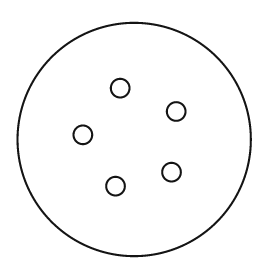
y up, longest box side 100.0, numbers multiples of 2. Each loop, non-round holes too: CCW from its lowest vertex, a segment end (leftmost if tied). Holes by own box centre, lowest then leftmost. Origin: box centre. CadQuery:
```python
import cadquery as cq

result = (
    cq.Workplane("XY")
    .moveTo(0.0, 0.0)
    .circle(50.0)
    .moveTo(-8.0, -20.0)
    .circle(4.0)
    .moveTo(16.0, -14.0)
    .circle(4.0)
    .moveTo(-22.0, 2.0)
    .circle(4.0)
    .moveTo(18.0, 12.0)
    .circle(4.0)
    .moveTo(-6.0, 22.0)
    .circle(4.0)
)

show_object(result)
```